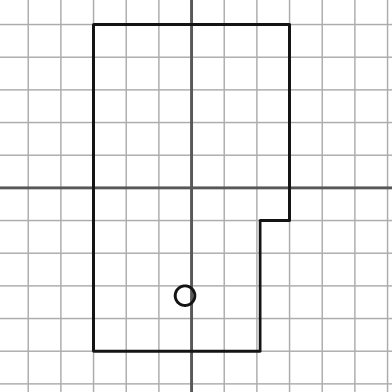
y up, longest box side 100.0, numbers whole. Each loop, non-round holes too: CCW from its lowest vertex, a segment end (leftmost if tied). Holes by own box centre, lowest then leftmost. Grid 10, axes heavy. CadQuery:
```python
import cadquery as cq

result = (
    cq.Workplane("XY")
    .moveTo(-30.0, -50.0)
    .lineTo(21.0, -50.0)
    .lineTo(21.0, -10.0)
    .lineTo(30.0, -10.0)
    .lineTo(30.0, 50.0)
    .lineTo(-30.0, 50.0)
    .close()
    .moveTo(-2.0, -33.0)
    .circle(3.0)
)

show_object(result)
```